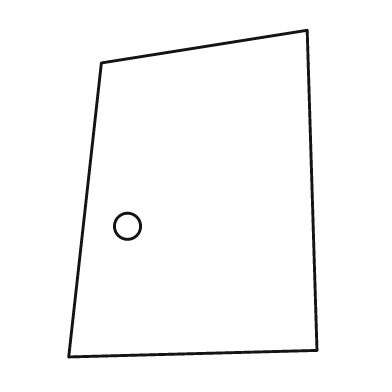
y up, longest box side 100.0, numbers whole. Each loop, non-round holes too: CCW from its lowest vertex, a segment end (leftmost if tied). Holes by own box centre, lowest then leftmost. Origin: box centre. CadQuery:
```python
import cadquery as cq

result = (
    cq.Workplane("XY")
    .moveTo(-38.0, -50.0)
    .lineTo(38.0, -48.0)
    .lineTo(35.0, 50.0)
    .lineTo(-28.0, 40.0)
    .close()
    .moveTo(-20.0, -10.0)
    .circle(4.0)
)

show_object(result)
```